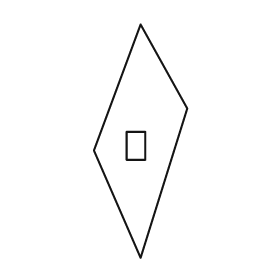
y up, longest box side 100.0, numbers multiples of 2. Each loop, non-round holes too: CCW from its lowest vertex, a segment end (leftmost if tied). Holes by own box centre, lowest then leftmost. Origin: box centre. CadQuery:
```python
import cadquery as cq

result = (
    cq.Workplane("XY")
    .moveTo(0.0, -50.0)
    .lineTo(20.0, 14.0)
    .lineTo(0.0, 50.0)
    .lineTo(-20.0, -4.0)
    .close()
    .moveTo(-6.0, -8.0)
    .lineTo(2.0, -8.0)
    .lineTo(2.0, 4.0)
    .lineTo(-6.0, 4.0)
    .close()
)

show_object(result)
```